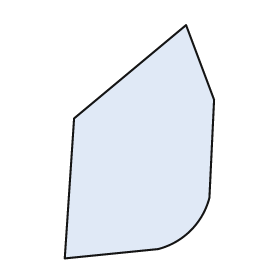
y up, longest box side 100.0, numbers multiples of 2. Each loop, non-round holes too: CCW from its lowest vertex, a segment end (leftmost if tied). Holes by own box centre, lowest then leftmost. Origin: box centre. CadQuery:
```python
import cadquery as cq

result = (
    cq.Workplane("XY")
    .moveTo(-32.0, -50.0)
    .lineTo(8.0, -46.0)
    .threePointArc((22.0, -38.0), (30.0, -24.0))
    .lineTo(32.0, 18.0)
    .lineTo(20.0, 50.0)
    .lineTo(-28.0, 10.0)
    .close()
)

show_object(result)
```